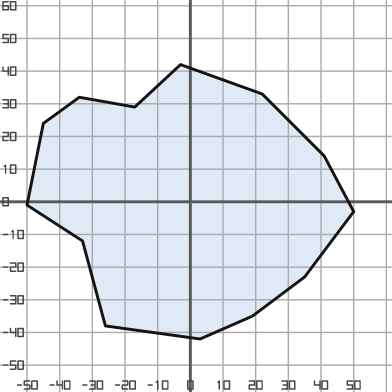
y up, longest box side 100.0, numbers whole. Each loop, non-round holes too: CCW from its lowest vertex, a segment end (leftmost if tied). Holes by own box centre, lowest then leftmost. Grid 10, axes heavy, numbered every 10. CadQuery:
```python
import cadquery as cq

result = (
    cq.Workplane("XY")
    .moveTo(3.0, -42.0)
    .lineTo(19.0, -35.0)
    .lineTo(35.0, -23.0)
    .lineTo(50.0, -3.0)
    .lineTo(41.0, 14.0)
    .lineTo(22.0, 33.0)
    .lineTo(-3.0, 42.0)
    .lineTo(-17.0, 29.0)
    .lineTo(-34.0, 32.0)
    .lineTo(-45.0, 24.0)
    .lineTo(-50.0, -1.0)
    .lineTo(-33.0, -12.0)
    .lineTo(-26.0, -38.0)
    .close()
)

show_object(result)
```